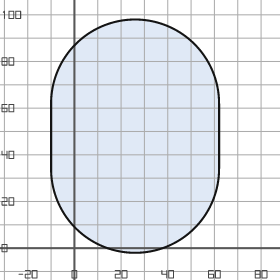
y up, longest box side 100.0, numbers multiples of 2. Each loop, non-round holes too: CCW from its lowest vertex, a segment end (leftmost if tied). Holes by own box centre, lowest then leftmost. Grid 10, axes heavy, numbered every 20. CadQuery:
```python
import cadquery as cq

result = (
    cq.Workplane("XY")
    .moveTo(-10.0, 34.0)
    .threePointArc((26.0, -2.0), (62.0, 34.0))
    .lineTo(62.0, 62.0)
    .threePointArc((26.0, 98.0), (-10.0, 62.0))
    .close()
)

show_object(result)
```